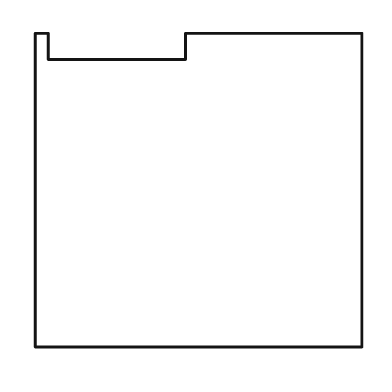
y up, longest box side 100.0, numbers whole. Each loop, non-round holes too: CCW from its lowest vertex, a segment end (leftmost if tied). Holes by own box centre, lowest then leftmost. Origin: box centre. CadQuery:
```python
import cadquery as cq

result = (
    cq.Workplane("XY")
    .moveTo(-50.0, -48.0)
    .lineTo(50.0, -48.0)
    .lineTo(50.0, 48.0)
    .lineTo(-4.0, 48.0)
    .lineTo(-4.0, 40.0)
    .lineTo(-46.0, 40.0)
    .lineTo(-46.0, 48.0)
    .lineTo(-50.0, 48.0)
    .close()
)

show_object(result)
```